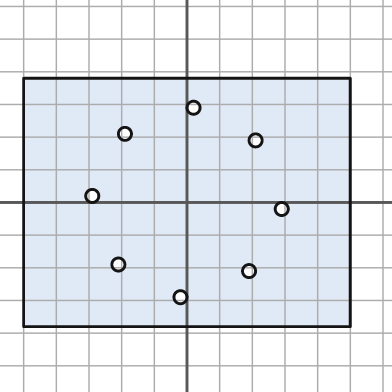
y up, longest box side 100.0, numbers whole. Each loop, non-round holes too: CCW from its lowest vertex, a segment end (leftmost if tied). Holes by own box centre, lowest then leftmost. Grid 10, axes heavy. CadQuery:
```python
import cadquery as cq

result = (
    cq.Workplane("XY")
    .moveTo(-50.0, -38.0)
    .lineTo(50.0, -38.0)
    .lineTo(50.0, 38.0)
    .lineTo(-50.0, 38.0)
    .close()
    .moveTo(-2.0, -29.0)
    .circle(2.0)
    .moveTo(19.0, -21.0)
    .circle(2.0)
    .moveTo(-21.0, -19.0)
    .circle(2.0)
    .moveTo(29.0, -2.0)
    .circle(2.0)
    .moveTo(-29.0, 2.0)
    .circle(2.0)
    .moveTo(21.0, 19.0)
    .circle(2.0)
    .moveTo(-19.0, 21.0)
    .circle(2.0)
    .moveTo(2.0, 29.0)
    .circle(2.0)
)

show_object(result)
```